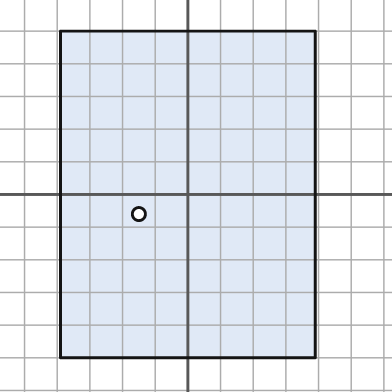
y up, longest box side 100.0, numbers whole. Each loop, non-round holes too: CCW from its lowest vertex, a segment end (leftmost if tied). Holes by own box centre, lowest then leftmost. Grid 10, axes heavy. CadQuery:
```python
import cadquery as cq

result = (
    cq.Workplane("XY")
    .moveTo(-39.0, -50.0)
    .lineTo(39.0, -50.0)
    .lineTo(39.0, 50.0)
    .lineTo(-39.0, 50.0)
    .close()
    .moveTo(-15.0, -6.0)
    .circle(2.0)
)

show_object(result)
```